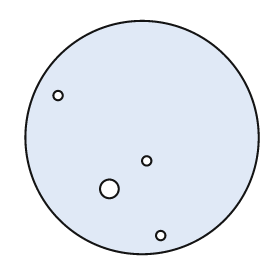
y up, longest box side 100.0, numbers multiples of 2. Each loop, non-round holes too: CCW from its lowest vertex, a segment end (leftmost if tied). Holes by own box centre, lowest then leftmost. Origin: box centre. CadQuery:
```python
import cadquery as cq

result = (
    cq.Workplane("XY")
    .moveTo(0.0, 0.0)
    .circle(50.0)
    .moveTo(8.0, -42.0)
    .circle(2.0)
    .moveTo(-14.0, -22.0)
    .circle(4.0)
    .moveTo(2.0, -10.0)
    .circle(2.0)
    .moveTo(-36.0, 18.0)
    .circle(2.0)
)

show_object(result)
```